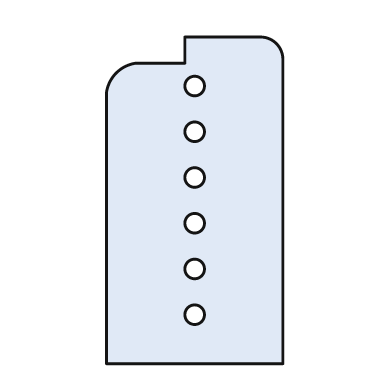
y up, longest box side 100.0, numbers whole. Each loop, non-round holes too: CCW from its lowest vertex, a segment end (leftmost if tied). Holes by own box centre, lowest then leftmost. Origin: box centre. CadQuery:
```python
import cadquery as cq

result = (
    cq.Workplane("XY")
    .moveTo(-27.0, -50.0)
    .lineTo(27.0, -50.0)
    .lineTo(27.0, 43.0)
    .threePointArc((25.0, 48.0), (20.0, 50.0))
    .lineTo(-3.0, 50.0)
    .lineTo(-3.0, 42.0)
    .lineTo(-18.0, 42.0)
    .threePointArc((-24.0, 39.0), (-27.0, 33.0))
    .close()
    .moveTo(0.0, -35.0)
    .circle(3.0)
    .moveTo(0.0, -21.0)
    .circle(3.0)
    .moveTo(0.0, -7.0)
    .circle(3.0)
    .moveTo(0.0, 7.0)
    .circle(3.0)
    .moveTo(0.0, 21.0)
    .circle(3.0)
    .moveTo(0.0, 35.0)
    .circle(3.0)
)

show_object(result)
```